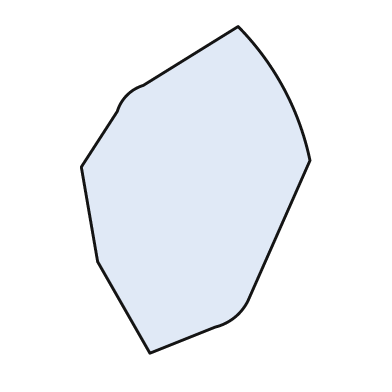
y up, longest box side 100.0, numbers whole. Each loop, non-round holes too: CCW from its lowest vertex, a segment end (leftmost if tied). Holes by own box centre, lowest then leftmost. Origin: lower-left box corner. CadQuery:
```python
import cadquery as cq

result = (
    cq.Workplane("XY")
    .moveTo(21.0, 0.0)
    .lineTo(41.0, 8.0)
    .threePointArc((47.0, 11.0), (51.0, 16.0))
    .lineTo(70.0, 59.0)
    .threePointArc((62.0, 81.0), (48.0, 100.0))
    .lineTo(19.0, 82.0)
    .threePointArc((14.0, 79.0), (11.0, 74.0))
    .lineTo(0.0, 57.0)
    .lineTo(5.0, 28.0)
    .close()
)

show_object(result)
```